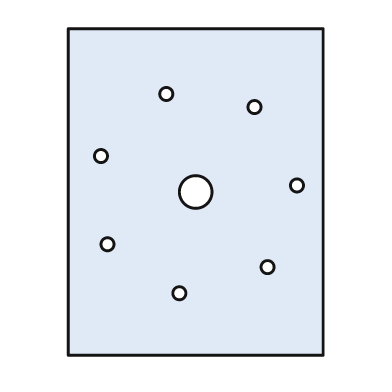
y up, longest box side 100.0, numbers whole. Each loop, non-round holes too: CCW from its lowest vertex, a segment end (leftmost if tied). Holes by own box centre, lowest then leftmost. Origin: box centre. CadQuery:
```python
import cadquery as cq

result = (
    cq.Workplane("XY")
    .moveTo(-39.0, -50.0)
    .lineTo(39.0, -50.0)
    .lineTo(39.0, 50.0)
    .lineTo(-39.0, 50.0)
    .close()
    .moveTo(-5.0, -31.0)
    .circle(2.0)
    .moveTo(22.0, -23.0)
    .circle(2.0)
    .moveTo(-27.0, -16.0)
    .circle(2.0)
    .moveTo(0.0, 0.0)
    .circle(5.0)
    .moveTo(31.0, 2.0)
    .circle(2.0)
    .moveTo(-29.0, 11.0)
    .circle(2.0)
    .moveTo(18.0, 26.0)
    .circle(2.0)
    .moveTo(-9.0, 30.0)
    .circle(2.0)
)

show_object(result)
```